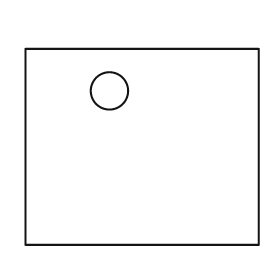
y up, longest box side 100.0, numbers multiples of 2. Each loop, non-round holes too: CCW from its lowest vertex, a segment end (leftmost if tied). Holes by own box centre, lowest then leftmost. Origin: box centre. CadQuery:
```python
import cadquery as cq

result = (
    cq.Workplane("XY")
    .moveTo(-50.0, -42.0)
    .lineTo(50.0, -42.0)
    .lineTo(50.0, 42.0)
    .lineTo(-50.0, 42.0)
    .close()
    .moveTo(-14.0, 24.0)
    .circle(8.0)
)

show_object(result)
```